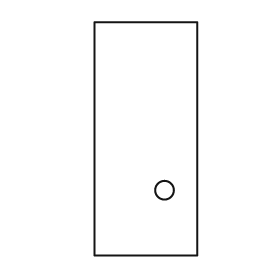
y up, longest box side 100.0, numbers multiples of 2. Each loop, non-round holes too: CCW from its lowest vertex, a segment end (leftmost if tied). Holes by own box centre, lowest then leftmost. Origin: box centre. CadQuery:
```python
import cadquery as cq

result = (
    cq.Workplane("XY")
    .moveTo(-22.0, -50.0)
    .lineTo(22.0, -50.0)
    .lineTo(22.0, 50.0)
    .lineTo(-22.0, 50.0)
    .close()
    .moveTo(8.0, -22.0)
    .circle(4.0)
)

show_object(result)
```